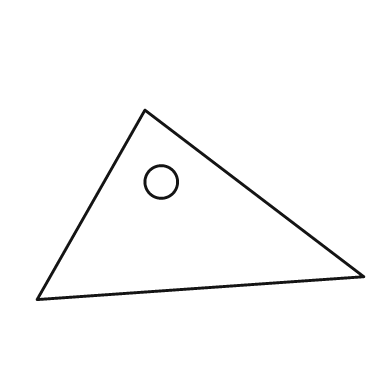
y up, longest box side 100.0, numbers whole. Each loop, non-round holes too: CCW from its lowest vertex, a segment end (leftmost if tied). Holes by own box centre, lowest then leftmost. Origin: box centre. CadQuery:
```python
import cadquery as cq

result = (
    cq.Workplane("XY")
    .moveTo(-50.0, -29.0)
    .lineTo(50.0, -22.0)
    .lineTo(-17.0, 29.0)
    .close()
    .moveTo(-12.0, 7.0)
    .circle(5.0)
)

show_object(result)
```